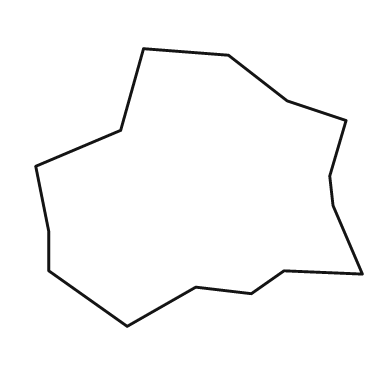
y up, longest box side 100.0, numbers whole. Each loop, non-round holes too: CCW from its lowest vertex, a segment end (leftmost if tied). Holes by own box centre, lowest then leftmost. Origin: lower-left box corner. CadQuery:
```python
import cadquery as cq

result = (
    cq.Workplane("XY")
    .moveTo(28.0, 0.0)
    .lineTo(49.0, 12.0)
    .lineTo(66.0, 10.0)
    .lineTo(76.0, 17.0)
    .lineTo(100.0, 16.0)
    .lineTo(91.0, 37.0)
    .lineTo(90.0, 46.0)
    .lineTo(95.0, 63.0)
    .lineTo(77.0, 69.0)
    .lineTo(59.0, 83.0)
    .lineTo(33.0, 85.0)
    .lineTo(26.0, 60.0)
    .lineTo(0.0, 49.0)
    .lineTo(4.0, 29.0)
    .lineTo(4.0, 17.0)
    .close()
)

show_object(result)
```